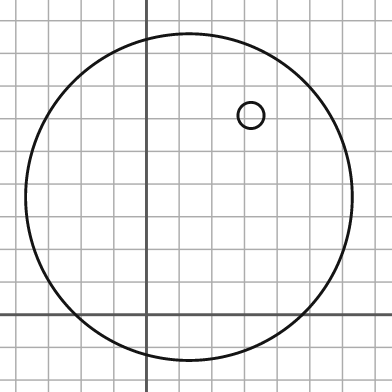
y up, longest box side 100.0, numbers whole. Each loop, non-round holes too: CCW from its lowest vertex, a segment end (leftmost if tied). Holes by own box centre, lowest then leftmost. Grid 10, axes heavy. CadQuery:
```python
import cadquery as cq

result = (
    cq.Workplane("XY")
    .moveTo(13.0, 36.0)
    .circle(50.0)
    .moveTo(32.0, 61.0)
    .circle(4.0)
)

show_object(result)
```